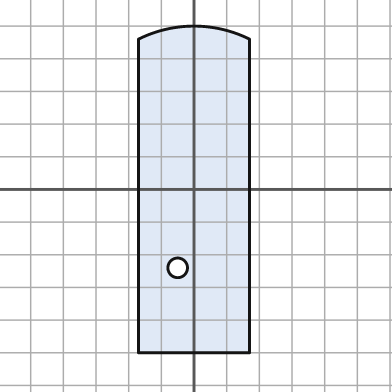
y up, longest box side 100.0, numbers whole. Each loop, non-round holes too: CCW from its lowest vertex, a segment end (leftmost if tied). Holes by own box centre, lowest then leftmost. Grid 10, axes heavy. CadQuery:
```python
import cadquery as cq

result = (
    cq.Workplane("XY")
    .moveTo(-17.0, -50.0)
    .lineTo(17.0, -50.0)
    .lineTo(17.0, 46.0)
    .threePointArc((0.0, 50.0), (-17.0, 46.0))
    .close()
    .moveTo(-5.0, -24.0)
    .circle(3.0)
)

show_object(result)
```